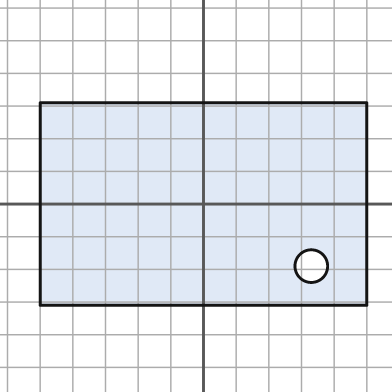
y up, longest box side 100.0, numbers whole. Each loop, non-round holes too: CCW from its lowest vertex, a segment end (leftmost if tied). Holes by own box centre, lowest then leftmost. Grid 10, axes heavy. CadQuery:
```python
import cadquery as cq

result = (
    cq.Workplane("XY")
    .moveTo(-50.0, -31.0)
    .lineTo(50.0, -31.0)
    .lineTo(50.0, 31.0)
    .lineTo(-50.0, 31.0)
    .close()
    .moveTo(33.0, -19.0)
    .circle(5.0)
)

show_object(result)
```